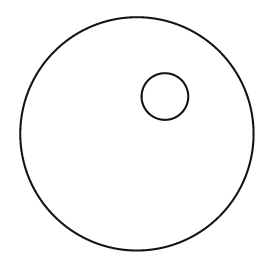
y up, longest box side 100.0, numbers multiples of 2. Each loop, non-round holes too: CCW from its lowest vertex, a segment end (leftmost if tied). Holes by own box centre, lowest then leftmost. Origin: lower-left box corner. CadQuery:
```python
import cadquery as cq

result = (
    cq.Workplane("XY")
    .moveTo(50.0, 50.0)
    .circle(50.0)
    .moveTo(62.0, 66.0)
    .circle(10.0)
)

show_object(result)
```